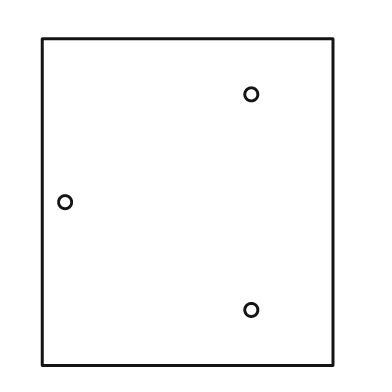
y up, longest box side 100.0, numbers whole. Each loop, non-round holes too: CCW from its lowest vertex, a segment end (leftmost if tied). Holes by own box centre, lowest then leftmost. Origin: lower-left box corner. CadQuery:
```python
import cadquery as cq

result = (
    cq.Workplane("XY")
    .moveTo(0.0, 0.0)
    .lineTo(89.0, 0.0)
    .lineTo(89.0, 100.0)
    .lineTo(0.0, 100.0)
    .close()
    .moveTo(64.0, 17.0)
    .circle(2.0)
    .moveTo(7.0, 50.0)
    .circle(2.0)
    .moveTo(64.0, 83.0)
    .circle(2.0)
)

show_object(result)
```